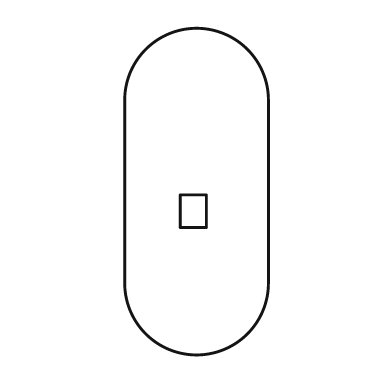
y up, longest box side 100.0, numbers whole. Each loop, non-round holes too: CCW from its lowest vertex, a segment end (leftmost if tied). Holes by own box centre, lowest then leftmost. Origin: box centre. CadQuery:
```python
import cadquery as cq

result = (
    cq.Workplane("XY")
    .moveTo(-22.0, -28.0)
    .threePointArc((0.0, -50.0), (22.0, -28.0))
    .lineTo(22.0, 28.0)
    .threePointArc((0.0, 50.0), (-22.0, 28.0))
    .close()
    .moveTo(-5.0, -11.0)
    .lineTo(3.0, -11.0)
    .lineTo(3.0, -1.0)
    .lineTo(-5.0, -1.0)
    .close()
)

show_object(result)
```